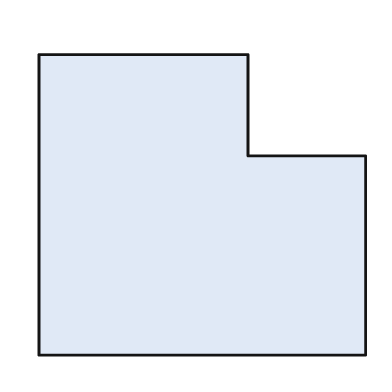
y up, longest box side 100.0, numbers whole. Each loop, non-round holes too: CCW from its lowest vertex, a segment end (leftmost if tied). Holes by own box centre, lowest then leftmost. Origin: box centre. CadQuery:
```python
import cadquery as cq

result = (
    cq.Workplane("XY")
    .moveTo(-50.0, -46.0)
    .lineTo(50.0, -46.0)
    .lineTo(50.0, 15.0)
    .lineTo(14.0, 15.0)
    .lineTo(14.0, 46.0)
    .lineTo(-50.0, 46.0)
    .close()
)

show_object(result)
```